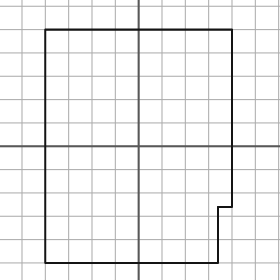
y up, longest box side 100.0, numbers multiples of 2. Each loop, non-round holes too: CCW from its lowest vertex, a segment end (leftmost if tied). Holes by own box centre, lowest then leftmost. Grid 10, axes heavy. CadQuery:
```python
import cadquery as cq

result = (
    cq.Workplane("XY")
    .moveTo(-40.0, -50.0)
    .lineTo(34.0, -50.0)
    .lineTo(34.0, -26.0)
    .lineTo(40.0, -26.0)
    .lineTo(40.0, 50.0)
    .lineTo(-40.0, 50.0)
    .close()
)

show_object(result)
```